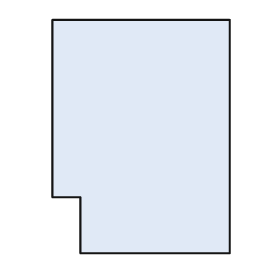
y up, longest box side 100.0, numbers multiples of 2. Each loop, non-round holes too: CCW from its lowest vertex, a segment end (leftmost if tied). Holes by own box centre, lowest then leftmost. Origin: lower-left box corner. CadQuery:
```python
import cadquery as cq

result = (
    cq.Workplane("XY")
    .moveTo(12.0, 0.0)
    .lineTo(76.0, 0.0)
    .lineTo(76.0, 100.0)
    .lineTo(0.0, 100.0)
    .lineTo(0.0, 24.0)
    .lineTo(12.0, 24.0)
    .close()
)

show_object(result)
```